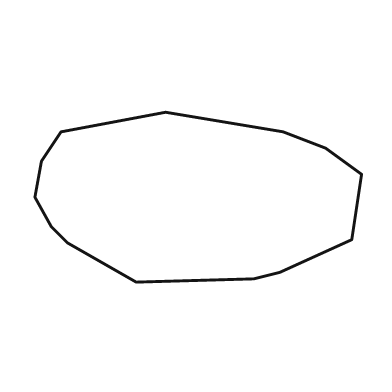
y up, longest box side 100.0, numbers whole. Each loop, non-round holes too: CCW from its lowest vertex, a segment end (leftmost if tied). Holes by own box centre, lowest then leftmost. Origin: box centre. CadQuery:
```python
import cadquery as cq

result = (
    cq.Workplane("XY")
    .moveTo(-19.0, -26.0)
    .lineTo(17.0, -25.0)
    .lineTo(25.0, -23.0)
    .lineTo(47.0, -13.0)
    .lineTo(50.0, 7.0)
    .lineTo(39.0, 15.0)
    .lineTo(26.0, 20.0)
    .lineTo(-10.0, 26.0)
    .lineTo(-42.0, 20.0)
    .lineTo(-48.0, 11.0)
    .lineTo(-50.0, 0.0)
    .lineTo(-45.0, -9.0)
    .lineTo(-40.0, -14.0)
    .close()
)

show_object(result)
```